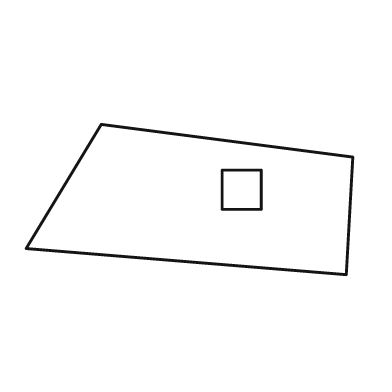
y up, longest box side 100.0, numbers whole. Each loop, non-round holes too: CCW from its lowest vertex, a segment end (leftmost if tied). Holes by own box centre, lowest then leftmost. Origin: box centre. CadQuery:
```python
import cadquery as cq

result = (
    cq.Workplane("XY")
    .moveTo(48.0, -23.0)
    .lineTo(50.0, 13.0)
    .lineTo(-27.0, 23.0)
    .lineTo(-50.0, -15.0)
    .close()
    .moveTo(10.0, -3.0)
    .lineTo(22.0, -3.0)
    .lineTo(22.0, 9.0)
    .lineTo(10.0, 9.0)
    .close()
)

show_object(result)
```